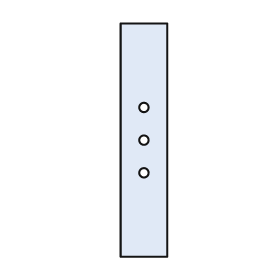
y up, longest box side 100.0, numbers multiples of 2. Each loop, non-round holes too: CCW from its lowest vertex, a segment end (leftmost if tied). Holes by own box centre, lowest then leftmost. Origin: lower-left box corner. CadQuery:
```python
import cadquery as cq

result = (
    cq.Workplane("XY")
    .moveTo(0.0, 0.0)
    .lineTo(20.0, 0.0)
    .lineTo(20.0, 100.0)
    .lineTo(0.0, 100.0)
    .close()
    .moveTo(10.0, 36.0)
    .circle(2.0)
    .moveTo(10.0, 50.0)
    .circle(2.0)
    .moveTo(10.0, 64.0)
    .circle(2.0)
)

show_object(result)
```